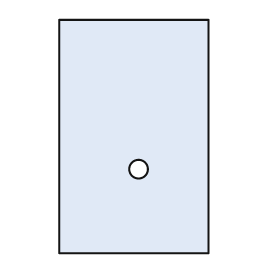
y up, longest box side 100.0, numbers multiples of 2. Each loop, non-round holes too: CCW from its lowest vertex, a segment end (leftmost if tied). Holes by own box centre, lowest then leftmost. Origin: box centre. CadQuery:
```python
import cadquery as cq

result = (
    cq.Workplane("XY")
    .moveTo(-32.0, -50.0)
    .lineTo(32.0, -50.0)
    .lineTo(32.0, 50.0)
    .lineTo(-32.0, 50.0)
    .close()
    .moveTo(2.0, -14.0)
    .circle(4.0)
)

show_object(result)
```